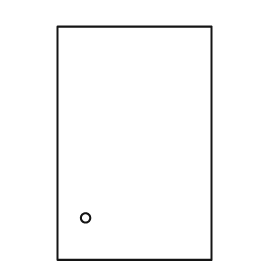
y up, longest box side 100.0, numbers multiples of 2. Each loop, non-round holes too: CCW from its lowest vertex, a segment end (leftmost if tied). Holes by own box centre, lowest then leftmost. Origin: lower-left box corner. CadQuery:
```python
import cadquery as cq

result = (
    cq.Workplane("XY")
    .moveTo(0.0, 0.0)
    .lineTo(66.0, 0.0)
    .lineTo(66.0, 100.0)
    .lineTo(0.0, 100.0)
    .close()
    .moveTo(12.0, 18.0)
    .circle(2.0)
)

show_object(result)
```